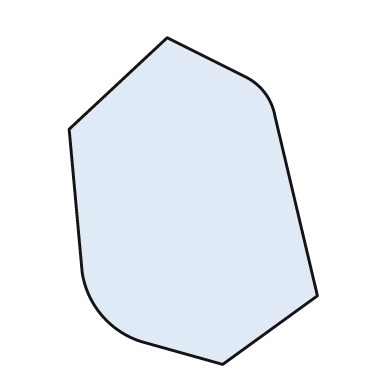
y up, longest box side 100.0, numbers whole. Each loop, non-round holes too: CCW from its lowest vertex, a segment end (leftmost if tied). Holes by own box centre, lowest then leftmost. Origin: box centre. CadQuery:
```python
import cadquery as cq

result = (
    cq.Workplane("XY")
    .moveTo(9.0, -50.0)
    .lineTo(38.0, -29.0)
    .lineTo(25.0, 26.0)
    .threePointArc((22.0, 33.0), (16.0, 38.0))
    .lineTo(-8.0, 50.0)
    .lineTo(-38.0, 22.0)
    .lineTo(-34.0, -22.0)
    .threePointArc((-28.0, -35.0), (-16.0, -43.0))
    .close()
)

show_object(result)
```